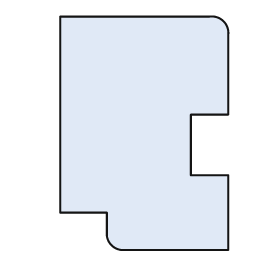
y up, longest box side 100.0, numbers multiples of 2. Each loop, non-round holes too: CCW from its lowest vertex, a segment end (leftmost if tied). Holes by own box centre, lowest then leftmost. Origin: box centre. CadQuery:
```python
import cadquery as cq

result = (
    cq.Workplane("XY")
    .moveTo(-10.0, -50.0)
    .lineTo(36.0, -50.0)
    .lineTo(36.0, -18.0)
    .lineTo(20.0, -18.0)
    .lineTo(20.0, 8.0)
    .lineTo(36.0, 8.0)
    .lineTo(36.0, 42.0)
    .threePointArc((34.0, 48.0), (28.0, 50.0))
    .lineTo(-36.0, 50.0)
    .lineTo(-36.0, -34.0)
    .lineTo(-16.0, -34.0)
    .lineTo(-16.0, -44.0)
    .threePointArc((-14.0, -48.0), (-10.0, -50.0))
    .close()
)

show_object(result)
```